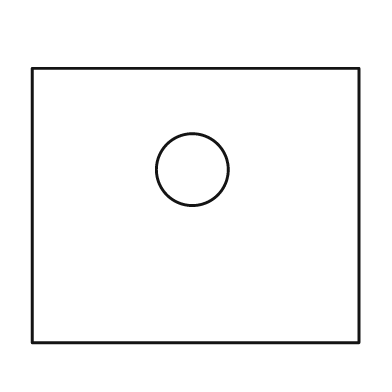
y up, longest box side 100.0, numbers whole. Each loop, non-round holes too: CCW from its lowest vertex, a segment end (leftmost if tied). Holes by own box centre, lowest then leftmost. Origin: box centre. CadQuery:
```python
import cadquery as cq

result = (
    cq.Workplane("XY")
    .moveTo(-50.0, -42.0)
    .lineTo(50.0, -42.0)
    .lineTo(50.0, 42.0)
    .lineTo(-50.0, 42.0)
    .close()
    .moveTo(-1.0, 11.0)
    .circle(11.0)
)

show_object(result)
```